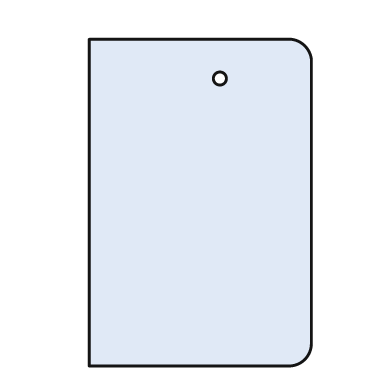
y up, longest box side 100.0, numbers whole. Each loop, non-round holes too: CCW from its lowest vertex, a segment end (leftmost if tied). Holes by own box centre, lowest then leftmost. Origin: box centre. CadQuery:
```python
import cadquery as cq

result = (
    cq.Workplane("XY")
    .moveTo(-34.0, -50.0)
    .lineTo(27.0, -50.0)
    .threePointArc((32.0, -48.0), (34.0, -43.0))
    .lineTo(34.0, 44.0)
    .threePointArc((32.0, 48.0), (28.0, 50.0))
    .lineTo(-34.0, 50.0)
    .close()
    .moveTo(6.0, 38.0)
    .circle(2.0)
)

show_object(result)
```